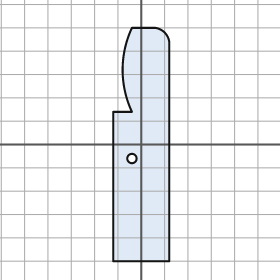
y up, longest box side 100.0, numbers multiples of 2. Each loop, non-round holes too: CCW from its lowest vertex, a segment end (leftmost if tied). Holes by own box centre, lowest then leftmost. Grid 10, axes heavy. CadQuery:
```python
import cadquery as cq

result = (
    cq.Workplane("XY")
    .moveTo(-12.0, -50.0)
    .lineTo(12.0, -50.0)
    .lineTo(12.0, 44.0)
    .threePointArc((10.0, 48.0), (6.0, 50.0))
    .lineTo(-4.0, 50.0)
    .threePointArc((-8.0, 32.0), (-4.0, 14.0))
    .lineTo(-12.0, 14.0)
    .close()
    .moveTo(-4.0, -6.0)
    .circle(2.0)
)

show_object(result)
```